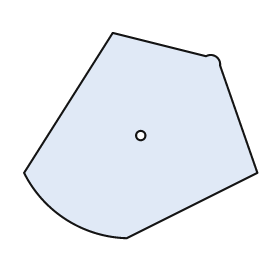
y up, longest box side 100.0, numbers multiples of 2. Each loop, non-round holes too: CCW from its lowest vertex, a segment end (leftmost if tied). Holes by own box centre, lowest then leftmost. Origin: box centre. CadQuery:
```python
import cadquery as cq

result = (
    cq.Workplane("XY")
    .moveTo(-6.0, -44.0)
    .lineTo(50.0, -16.0)
    .lineTo(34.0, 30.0)
    .threePointArc((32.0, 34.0), (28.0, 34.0))
    .lineTo(-12.0, 44.0)
    .lineTo(-50.0, -16.0)
    .threePointArc((-32.0, -36.0), (-6.0, -44.0))
    .close()
    .moveTo(0.0, 0.0)
    .circle(2.0)
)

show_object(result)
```